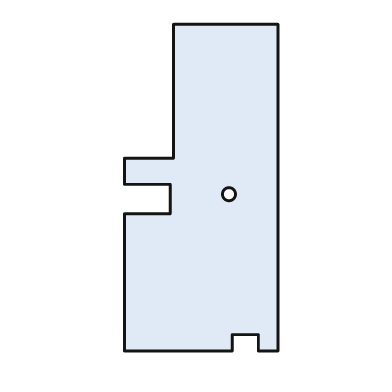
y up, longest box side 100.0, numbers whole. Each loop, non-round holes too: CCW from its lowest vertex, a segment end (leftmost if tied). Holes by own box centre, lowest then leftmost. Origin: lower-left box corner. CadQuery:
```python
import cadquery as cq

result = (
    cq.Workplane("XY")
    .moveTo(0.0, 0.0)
    .lineTo(33.0, 0.0)
    .lineTo(33.0, 5.0)
    .lineTo(41.0, 5.0)
    .lineTo(41.0, 0.0)
    .lineTo(47.0, 0.0)
    .lineTo(47.0, 100.0)
    .lineTo(15.0, 100.0)
    .lineTo(15.0, 59.0)
    .lineTo(0.0, 59.0)
    .lineTo(0.0, 51.0)
    .lineTo(14.0, 51.0)
    .lineTo(14.0, 42.0)
    .lineTo(0.0, 42.0)
    .close()
    .moveTo(32.0, 48.0)
    .circle(2.0)
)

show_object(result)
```